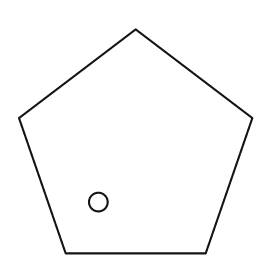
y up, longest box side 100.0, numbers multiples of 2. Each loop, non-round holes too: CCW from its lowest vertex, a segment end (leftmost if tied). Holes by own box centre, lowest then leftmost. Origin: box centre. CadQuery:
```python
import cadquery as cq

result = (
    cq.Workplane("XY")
    .moveTo(-30.0, -48.0)
    .lineTo(30.0, -48.0)
    .lineTo(50.0, 10.0)
    .lineTo(0.0, 48.0)
    .lineTo(-50.0, 10.0)
    .close()
    .moveTo(-16.0, -26.0)
    .circle(4.0)
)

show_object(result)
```